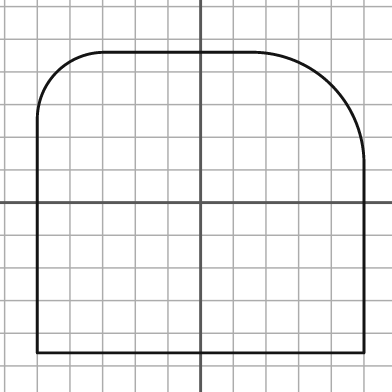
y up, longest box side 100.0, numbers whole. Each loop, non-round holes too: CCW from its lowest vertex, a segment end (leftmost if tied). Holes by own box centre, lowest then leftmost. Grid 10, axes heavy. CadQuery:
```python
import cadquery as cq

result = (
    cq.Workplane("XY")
    .moveTo(-50.0, -46.0)
    .lineTo(50.0, -46.0)
    .lineTo(50.0, 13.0)
    .threePointArc((40.0, 36.0), (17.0, 46.0))
    .lineTo(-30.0, 46.0)
    .threePointArc((-44.0, 40.0), (-50.0, 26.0))
    .close()
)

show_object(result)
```